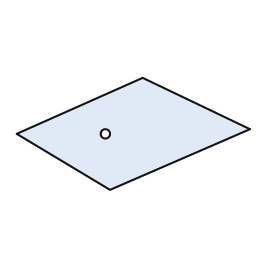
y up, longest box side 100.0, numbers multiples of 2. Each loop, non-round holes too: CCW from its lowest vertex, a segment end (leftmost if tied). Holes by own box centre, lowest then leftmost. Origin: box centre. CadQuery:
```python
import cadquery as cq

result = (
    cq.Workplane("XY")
    .moveTo(-10.0, -24.0)
    .lineTo(50.0, 2.0)
    .lineTo(4.0, 24.0)
    .lineTo(-50.0, 0.0)
    .close()
    .moveTo(-12.0, 0.0)
    .circle(2.0)
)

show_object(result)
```